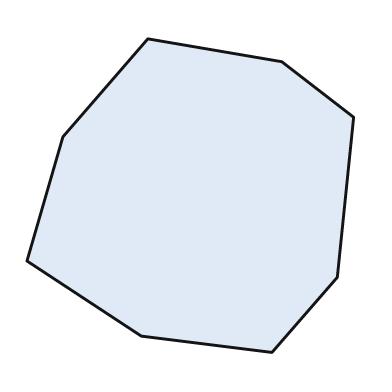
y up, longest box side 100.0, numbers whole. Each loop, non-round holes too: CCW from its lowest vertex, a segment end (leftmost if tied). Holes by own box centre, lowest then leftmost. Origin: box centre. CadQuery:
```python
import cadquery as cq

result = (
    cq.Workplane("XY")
    .moveTo(25.0, -48.0)
    .lineTo(45.0, -25.0)
    .lineTo(50.0, 24.0)
    .lineTo(28.0, 41.0)
    .lineTo(-13.0, 48.0)
    .lineTo(-39.0, 18.0)
    .lineTo(-50.0, -20.0)
    .lineTo(-15.0, -43.0)
    .close()
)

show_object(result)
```